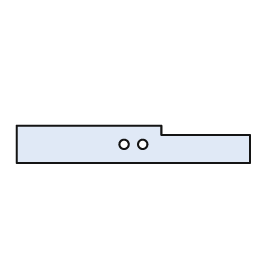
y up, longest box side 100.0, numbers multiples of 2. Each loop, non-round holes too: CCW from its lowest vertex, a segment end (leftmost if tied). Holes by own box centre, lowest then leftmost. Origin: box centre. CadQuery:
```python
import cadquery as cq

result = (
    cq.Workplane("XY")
    .moveTo(-50.0, -8.0)
    .lineTo(50.0, -8.0)
    .lineTo(50.0, 4.0)
    .lineTo(12.0, 4.0)
    .lineTo(12.0, 8.0)
    .lineTo(-50.0, 8.0)
    .close()
    .moveTo(-4.0, 0.0)
    .circle(2.0)
    .moveTo(4.0, 0.0)
    .circle(2.0)
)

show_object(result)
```